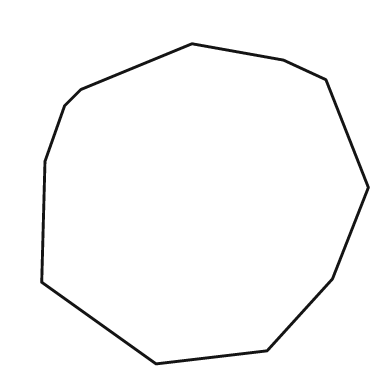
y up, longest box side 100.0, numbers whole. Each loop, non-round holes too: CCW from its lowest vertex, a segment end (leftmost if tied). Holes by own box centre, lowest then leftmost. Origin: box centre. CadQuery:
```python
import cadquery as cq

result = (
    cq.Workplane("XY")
    .moveTo(-15.0, -49.0)
    .lineTo(19.0, -45.0)
    .lineTo(39.0, -23.0)
    .lineTo(50.0, 5.0)
    .lineTo(37.0, 38.0)
    .lineTo(24.0, 44.0)
    .lineTo(-4.0, 49.0)
    .lineTo(-38.0, 35.0)
    .lineTo(-43.0, 30.0)
    .lineTo(-49.0, 13.0)
    .lineTo(-50.0, -24.0)
    .close()
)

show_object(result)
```